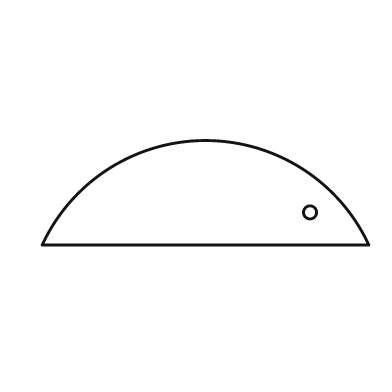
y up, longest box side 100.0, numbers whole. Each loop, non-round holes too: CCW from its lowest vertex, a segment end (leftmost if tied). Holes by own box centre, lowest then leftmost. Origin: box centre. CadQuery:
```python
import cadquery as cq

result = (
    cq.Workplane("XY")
    .moveTo(-50.0, -16.0)
    .lineTo(50.0, -16.0)
    .threePointArc((0.0, 16.0), (-50.0, -16.0))
    .close()
    .moveTo(32.0, -6.0)
    .circle(2.0)
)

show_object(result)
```